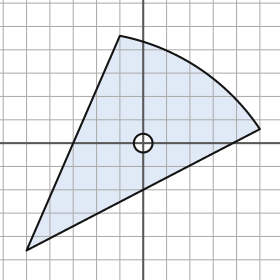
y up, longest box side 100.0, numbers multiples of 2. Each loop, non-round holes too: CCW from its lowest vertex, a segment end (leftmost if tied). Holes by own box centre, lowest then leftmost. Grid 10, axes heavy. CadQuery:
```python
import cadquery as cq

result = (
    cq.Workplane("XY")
    .moveTo(-50.0, -46.0)
    .lineTo(50.0, 6.0)
    .threePointArc((24.0, 32.0), (-10.0, 46.0))
    .close()
    .moveTo(0.0, 0.0)
    .circle(4.0)
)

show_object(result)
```